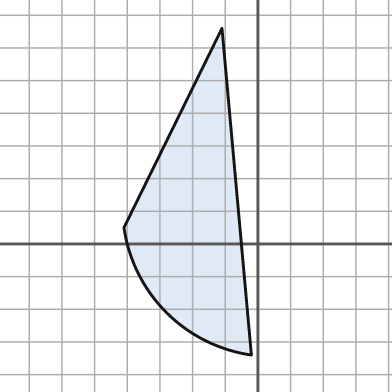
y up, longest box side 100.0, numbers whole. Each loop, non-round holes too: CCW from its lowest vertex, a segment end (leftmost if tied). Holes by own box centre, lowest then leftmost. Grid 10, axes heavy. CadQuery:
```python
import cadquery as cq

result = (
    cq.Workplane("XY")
    .moveTo(-2.0, -34.0)
    .lineTo(-11.0, 66.0)
    .lineTo(-41.0, 5.0)
    .threePointArc((-28.0, -21.0), (-2.0, -34.0))
    .close()
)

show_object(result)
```